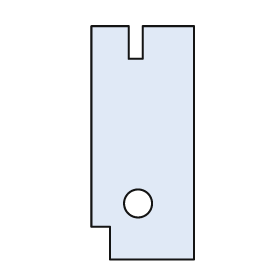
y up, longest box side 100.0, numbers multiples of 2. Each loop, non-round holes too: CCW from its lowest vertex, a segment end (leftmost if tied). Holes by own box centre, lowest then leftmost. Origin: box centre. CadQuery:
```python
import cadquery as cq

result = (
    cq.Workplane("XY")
    .moveTo(-14.0, -50.0)
    .lineTo(22.0, -50.0)
    .lineTo(22.0, 50.0)
    .lineTo(0.0, 50.0)
    .lineTo(0.0, 36.0)
    .lineTo(-6.0, 36.0)
    .lineTo(-6.0, 50.0)
    .lineTo(-22.0, 50.0)
    .lineTo(-22.0, -36.0)
    .lineTo(-14.0, -36.0)
    .close()
    .moveTo(-2.0, -26.0)
    .circle(6.0)
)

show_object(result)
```